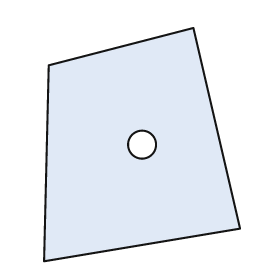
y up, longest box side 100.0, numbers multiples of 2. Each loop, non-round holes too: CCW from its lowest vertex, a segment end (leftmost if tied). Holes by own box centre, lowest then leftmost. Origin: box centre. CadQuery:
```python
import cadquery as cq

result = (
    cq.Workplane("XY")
    .moveTo(-42.0, -50.0)
    .lineTo(42.0, -36.0)
    .lineTo(22.0, 50.0)
    .lineTo(-40.0, 34.0)
    .close()
    .moveTo(0.0, 0.0)
    .circle(6.0)
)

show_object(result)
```